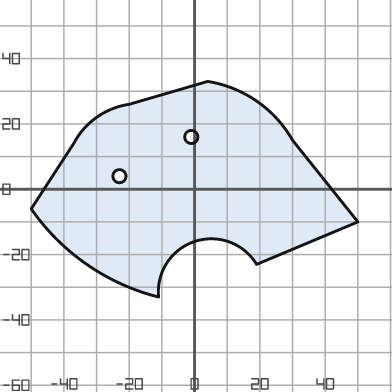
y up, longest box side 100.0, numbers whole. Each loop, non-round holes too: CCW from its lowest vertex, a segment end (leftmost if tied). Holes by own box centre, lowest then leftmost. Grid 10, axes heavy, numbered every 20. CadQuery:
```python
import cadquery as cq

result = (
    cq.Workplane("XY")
    .moveTo(-11.0, -33.0)
    .threePointArc((0.0, -16.0), (19.0, -23.0))
    .lineTo(50.0, -10.0)
    .lineTo(30.0, 15.0)
    .threePointArc((19.0, 27.0), (4.0, 33.0))
    .lineTo(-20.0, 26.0)
    .threePointArc((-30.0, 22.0), (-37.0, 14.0))
    .lineTo(-50.0, -6.0)
    .threePointArc((-33.0, -23.0), (-11.0, -33.0))
    .close()
    .moveTo(-23.0, 4.0)
    .circle(2.0)
    .moveTo(-1.0, 16.0)
    .circle(2.0)
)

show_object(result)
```